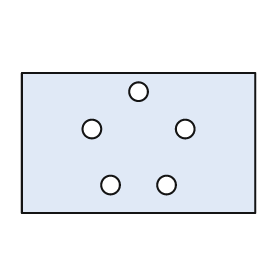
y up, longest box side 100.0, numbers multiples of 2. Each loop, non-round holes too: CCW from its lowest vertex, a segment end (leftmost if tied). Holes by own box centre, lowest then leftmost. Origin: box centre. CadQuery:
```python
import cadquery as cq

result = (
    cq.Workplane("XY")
    .moveTo(-50.0, -30.0)
    .lineTo(50.0, -30.0)
    .lineTo(50.0, 30.0)
    .lineTo(-50.0, 30.0)
    .close()
    .moveTo(-12.0, -18.0)
    .circle(4.0)
    .moveTo(12.0, -18.0)
    .circle(4.0)
    .moveTo(-20.0, 6.0)
    .circle(4.0)
    .moveTo(20.0, 6.0)
    .circle(4.0)
    .moveTo(0.0, 22.0)
    .circle(4.0)
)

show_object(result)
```